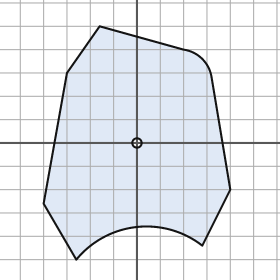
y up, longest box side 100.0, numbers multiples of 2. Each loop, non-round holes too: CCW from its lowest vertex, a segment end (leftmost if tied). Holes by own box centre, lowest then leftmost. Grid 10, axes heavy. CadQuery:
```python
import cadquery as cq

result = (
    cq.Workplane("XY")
    .moveTo(-26.0, -50.0)
    .threePointArc((0.0, -36.0), (28.0, -44.0))
    .lineTo(40.0, -20.0)
    .lineTo(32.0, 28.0)
    .threePointArc((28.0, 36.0), (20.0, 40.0))
    .lineTo(-16.0, 50.0)
    .lineTo(-30.0, 30.0)
    .lineTo(-40.0, -26.0)
    .close()
    .moveTo(0.0, 0.0)
    .circle(2.0)
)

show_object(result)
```